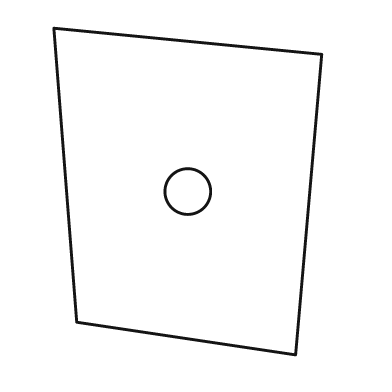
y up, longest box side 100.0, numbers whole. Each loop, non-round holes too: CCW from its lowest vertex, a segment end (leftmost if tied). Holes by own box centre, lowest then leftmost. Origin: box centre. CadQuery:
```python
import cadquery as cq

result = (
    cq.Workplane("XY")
    .moveTo(33.0, -50.0)
    .lineTo(41.0, 42.0)
    .lineTo(-41.0, 50.0)
    .lineTo(-34.0, -40.0)
    .close()
    .moveTo(0.0, 0.0)
    .circle(7.0)
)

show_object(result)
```